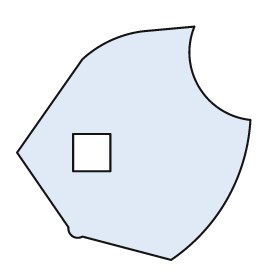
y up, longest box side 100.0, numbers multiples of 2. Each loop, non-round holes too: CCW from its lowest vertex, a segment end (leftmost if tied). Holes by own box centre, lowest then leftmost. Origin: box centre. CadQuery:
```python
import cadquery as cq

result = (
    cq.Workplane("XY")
    .moveTo(16.0, -50.0)
    .threePointArc((40.0, -24.0), (50.0, 10.0))
    .threePointArc((28.0, 24.0), (26.0, 50.0))
    .lineTo(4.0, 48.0)
    .threePointArc((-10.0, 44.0), (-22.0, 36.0))
    .lineTo(-50.0, -4.0)
    .lineTo(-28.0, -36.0)
    .threePointArc((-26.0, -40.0), (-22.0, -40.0))
    .close()
    .moveTo(-26.0, -12.0)
    .lineTo(-10.0, -12.0)
    .lineTo(-10.0, 4.0)
    .lineTo(-26.0, 4.0)
    .close()
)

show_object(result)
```